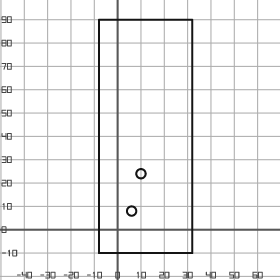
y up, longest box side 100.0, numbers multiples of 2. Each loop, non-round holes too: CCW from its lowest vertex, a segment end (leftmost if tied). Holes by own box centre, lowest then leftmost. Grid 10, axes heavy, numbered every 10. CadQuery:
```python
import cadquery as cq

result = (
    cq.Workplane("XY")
    .moveTo(-8.0, -10.0)
    .lineTo(32.0, -10.0)
    .lineTo(32.0, 90.0)
    .lineTo(-8.0, 90.0)
    .close()
    .moveTo(6.0, 8.0)
    .circle(2.0)
    .moveTo(10.0, 24.0)
    .circle(2.0)
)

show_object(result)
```